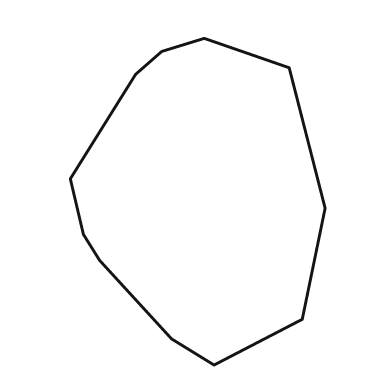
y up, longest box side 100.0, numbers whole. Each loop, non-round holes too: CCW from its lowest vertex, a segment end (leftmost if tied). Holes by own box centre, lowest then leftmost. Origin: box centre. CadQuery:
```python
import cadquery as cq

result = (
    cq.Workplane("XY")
    .moveTo(5.0, -50.0)
    .lineTo(32.0, -36.0)
    .lineTo(39.0, -2.0)
    .lineTo(28.0, 41.0)
    .lineTo(2.0, 50.0)
    .lineTo(-11.0, 46.0)
    .lineTo(-19.0, 39.0)
    .lineTo(-39.0, 7.0)
    .lineTo(-35.0, -10.0)
    .lineTo(-30.0, -18.0)
    .lineTo(-8.0, -42.0)
    .close()
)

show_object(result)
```